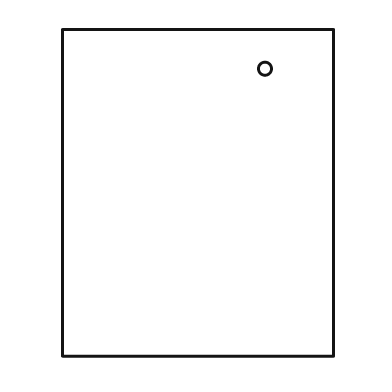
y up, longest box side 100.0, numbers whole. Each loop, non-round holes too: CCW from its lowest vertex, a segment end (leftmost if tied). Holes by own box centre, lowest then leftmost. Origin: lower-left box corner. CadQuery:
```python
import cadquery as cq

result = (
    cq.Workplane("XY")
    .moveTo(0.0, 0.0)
    .lineTo(83.0, 0.0)
    .lineTo(83.0, 100.0)
    .lineTo(0.0, 100.0)
    .close()
    .moveTo(62.0, 88.0)
    .circle(2.0)
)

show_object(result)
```